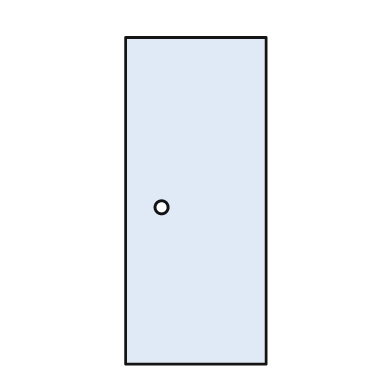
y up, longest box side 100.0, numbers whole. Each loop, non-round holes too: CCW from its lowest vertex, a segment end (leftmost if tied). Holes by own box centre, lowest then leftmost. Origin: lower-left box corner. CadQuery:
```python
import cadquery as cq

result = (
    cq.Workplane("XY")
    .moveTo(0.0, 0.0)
    .lineTo(43.0, 0.0)
    .lineTo(43.0, 100.0)
    .lineTo(0.0, 100.0)
    .close()
    .moveTo(11.0, 48.0)
    .circle(2.0)
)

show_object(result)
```